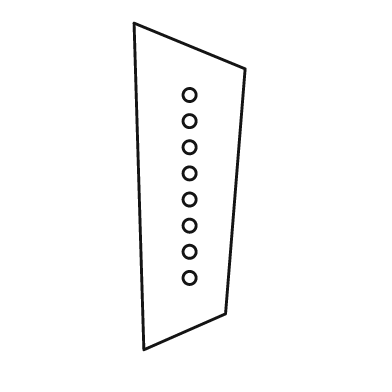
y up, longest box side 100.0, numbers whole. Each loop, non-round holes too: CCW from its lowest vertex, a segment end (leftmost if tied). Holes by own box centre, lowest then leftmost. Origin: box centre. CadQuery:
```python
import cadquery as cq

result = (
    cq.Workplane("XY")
    .moveTo(-14.0, -50.0)
    .lineTo(11.0, -39.0)
    .lineTo(17.0, 36.0)
    .lineTo(-17.0, 50.0)
    .close()
    .moveTo(0.0, -28.0)
    .circle(2.0)
    .moveTo(0.0, -20.0)
    .circle(2.0)
    .moveTo(0.0, -12.0)
    .circle(2.0)
    .moveTo(0.0, -4.0)
    .circle(2.0)
    .moveTo(0.0, 4.0)
    .circle(2.0)
    .moveTo(0.0, 12.0)
    .circle(2.0)
    .moveTo(0.0, 20.0)
    .circle(2.0)
    .moveTo(0.0, 28.0)
    .circle(2.0)
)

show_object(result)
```